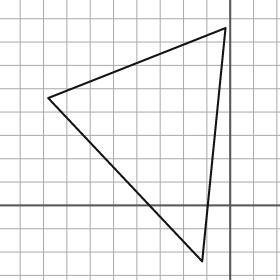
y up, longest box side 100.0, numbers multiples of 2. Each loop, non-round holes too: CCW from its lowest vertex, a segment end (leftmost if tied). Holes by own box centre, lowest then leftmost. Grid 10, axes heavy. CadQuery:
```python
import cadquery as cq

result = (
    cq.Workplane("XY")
    .moveTo(-12.0, -24.0)
    .lineTo(-2.0, 76.0)
    .lineTo(-78.0, 46.0)
    .close()
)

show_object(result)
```